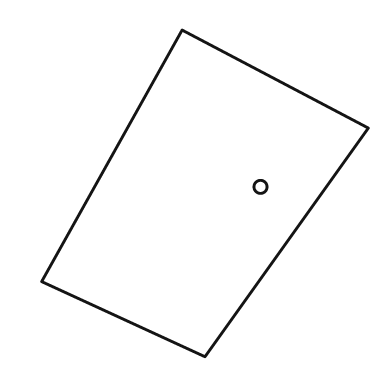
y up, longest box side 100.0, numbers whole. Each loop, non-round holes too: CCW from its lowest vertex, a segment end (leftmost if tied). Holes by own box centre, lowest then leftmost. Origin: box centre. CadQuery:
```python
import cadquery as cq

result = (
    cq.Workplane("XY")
    .moveTo(0.0, -50.0)
    .lineTo(50.0, 20.0)
    .lineTo(-7.0, 50.0)
    .lineTo(-50.0, -27.0)
    .close()
    .moveTo(17.0, 2.0)
    .circle(2.0)
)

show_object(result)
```